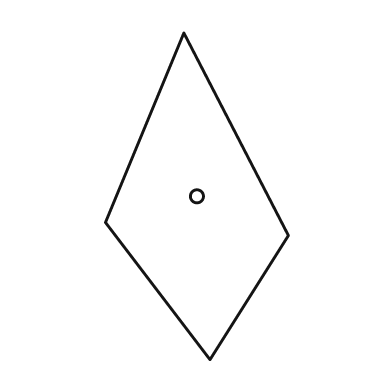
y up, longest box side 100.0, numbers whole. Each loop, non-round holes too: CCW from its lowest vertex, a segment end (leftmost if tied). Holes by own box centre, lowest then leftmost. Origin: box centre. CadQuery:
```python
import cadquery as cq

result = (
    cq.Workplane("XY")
    .moveTo(4.0, -50.0)
    .lineTo(28.0, -12.0)
    .lineTo(-4.0, 50.0)
    .lineTo(-28.0, -8.0)
    .close()
    .moveTo(0.0, 0.0)
    .circle(2.0)
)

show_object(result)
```